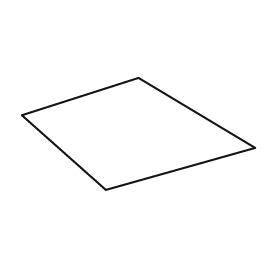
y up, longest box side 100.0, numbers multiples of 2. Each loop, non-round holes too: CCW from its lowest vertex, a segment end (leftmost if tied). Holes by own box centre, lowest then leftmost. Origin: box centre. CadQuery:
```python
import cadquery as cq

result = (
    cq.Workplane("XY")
    .moveTo(-14.0, -24.0)
    .lineTo(50.0, -6.0)
    .lineTo(0.0, 24.0)
    .lineTo(-50.0, 8.0)
    .close()
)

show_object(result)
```